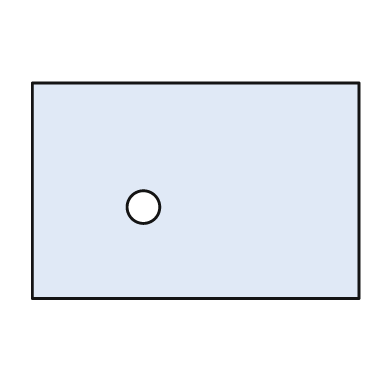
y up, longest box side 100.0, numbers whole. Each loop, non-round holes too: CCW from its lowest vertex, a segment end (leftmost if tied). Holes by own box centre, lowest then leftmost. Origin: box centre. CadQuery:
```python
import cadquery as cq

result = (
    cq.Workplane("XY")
    .moveTo(-50.0, -33.0)
    .lineTo(50.0, -33.0)
    .lineTo(50.0, 33.0)
    .lineTo(-50.0, 33.0)
    .close()
    .moveTo(-16.0, -5.0)
    .circle(5.0)
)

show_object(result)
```